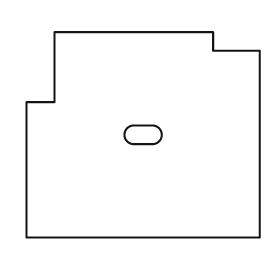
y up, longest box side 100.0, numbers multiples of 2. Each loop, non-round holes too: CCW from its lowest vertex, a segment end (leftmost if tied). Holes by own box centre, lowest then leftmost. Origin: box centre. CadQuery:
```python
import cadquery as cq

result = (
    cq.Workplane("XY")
    .moveTo(-50.0, -44.0)
    .lineTo(50.0, -44.0)
    .lineTo(50.0, 36.0)
    .lineTo(30.0, 36.0)
    .lineTo(30.0, 44.0)
    .lineTo(-38.0, 44.0)
    .lineTo(-38.0, 14.0)
    .lineTo(-50.0, 14.0)
    .close()
    .moveTo(-4.0, -4.0)
    .lineTo(4.0, -4.0)
    .threePointArc((8.0, 0.0), (4.0, 4.0))
    .lineTo(-4.0, 4.0)
    .threePointArc((-8.0, 0.0), (-4.0, -4.0))
    .close()
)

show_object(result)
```